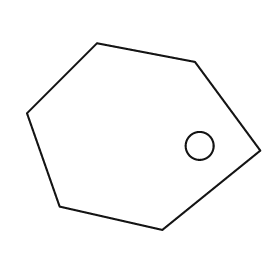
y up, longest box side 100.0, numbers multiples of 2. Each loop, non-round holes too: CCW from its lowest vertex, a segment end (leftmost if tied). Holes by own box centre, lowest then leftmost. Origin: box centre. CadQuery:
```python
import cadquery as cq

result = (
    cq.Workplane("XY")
    .moveTo(8.0, -40.0)
    .lineTo(50.0, -6.0)
    .lineTo(22.0, 32.0)
    .lineTo(-20.0, 40.0)
    .lineTo(-50.0, 10.0)
    .lineTo(-36.0, -30.0)
    .close()
    .moveTo(24.0, -4.0)
    .circle(6.0)
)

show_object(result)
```